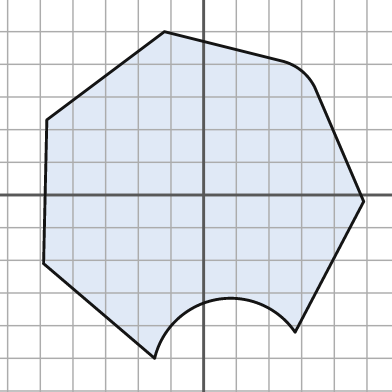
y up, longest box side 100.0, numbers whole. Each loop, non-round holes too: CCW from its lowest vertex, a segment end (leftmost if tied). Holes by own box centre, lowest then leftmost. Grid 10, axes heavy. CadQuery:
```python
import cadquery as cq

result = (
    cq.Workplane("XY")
    .moveTo(-15.0, -50.0)
    .threePointArc((4.0, -32.0), (28.0, -42.0))
    .lineTo(49.0, -2.0)
    .lineTo(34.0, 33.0)
    .threePointArc((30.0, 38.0), (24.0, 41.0))
    .lineTo(-12.0, 50.0)
    .lineTo(-48.0, 23.0)
    .lineTo(-49.0, -21.0)
    .close()
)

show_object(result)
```